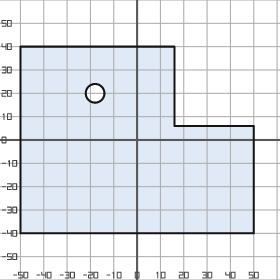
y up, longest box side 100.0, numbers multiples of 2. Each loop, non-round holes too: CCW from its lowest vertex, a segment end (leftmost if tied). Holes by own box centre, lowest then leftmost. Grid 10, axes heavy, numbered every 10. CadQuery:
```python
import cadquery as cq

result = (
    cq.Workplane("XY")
    .moveTo(-50.0, -40.0)
    .lineTo(50.0, -40.0)
    .lineTo(50.0, 6.0)
    .lineTo(16.0, 6.0)
    .lineTo(16.0, 40.0)
    .lineTo(-50.0, 40.0)
    .close()
    .moveTo(-18.0, 20.0)
    .circle(4.0)
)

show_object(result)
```